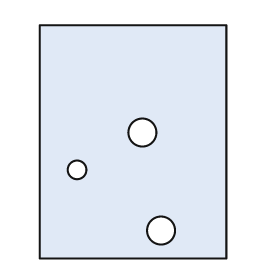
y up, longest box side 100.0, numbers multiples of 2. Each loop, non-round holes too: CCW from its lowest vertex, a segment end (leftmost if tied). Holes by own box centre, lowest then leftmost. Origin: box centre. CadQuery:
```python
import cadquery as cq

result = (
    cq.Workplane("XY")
    .moveTo(-40.0, -50.0)
    .lineTo(40.0, -50.0)
    .lineTo(40.0, 50.0)
    .lineTo(-40.0, 50.0)
    .close()
    .moveTo(12.0, -38.0)
    .circle(6.0)
    .moveTo(-24.0, -12.0)
    .circle(4.0)
    .moveTo(4.0, 4.0)
    .circle(6.0)
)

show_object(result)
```